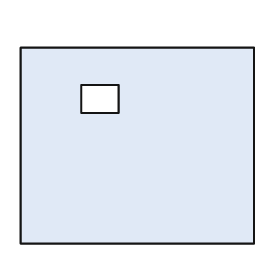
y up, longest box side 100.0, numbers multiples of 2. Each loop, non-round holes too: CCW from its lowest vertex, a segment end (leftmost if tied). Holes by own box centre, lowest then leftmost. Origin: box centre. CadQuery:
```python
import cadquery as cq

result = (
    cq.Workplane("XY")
    .moveTo(-50.0, -42.0)
    .lineTo(50.0, -42.0)
    .lineTo(50.0, 42.0)
    .lineTo(-50.0, 42.0)
    .close()
    .moveTo(-24.0, 14.0)
    .lineTo(-8.0, 14.0)
    .lineTo(-8.0, 26.0)
    .lineTo(-24.0, 26.0)
    .close()
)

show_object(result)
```